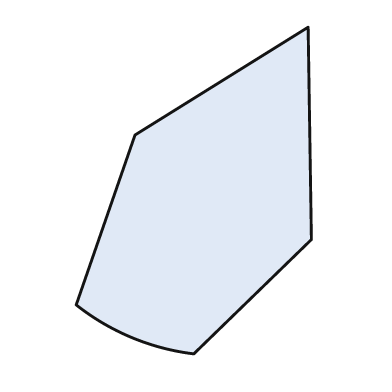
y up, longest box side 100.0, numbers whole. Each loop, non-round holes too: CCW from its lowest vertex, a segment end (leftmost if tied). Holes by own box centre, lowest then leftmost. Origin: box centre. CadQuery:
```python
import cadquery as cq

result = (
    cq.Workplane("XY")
    .moveTo(0.0, -50.0)
    .lineTo(36.0, -15.0)
    .lineTo(35.0, 50.0)
    .lineTo(-18.0, 17.0)
    .lineTo(-36.0, -35.0)
    .threePointArc((-19.0, -45.0), (0.0, -50.0))
    .close()
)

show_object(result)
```